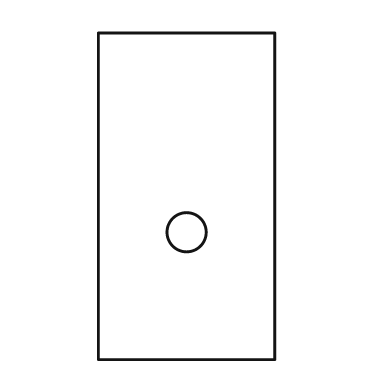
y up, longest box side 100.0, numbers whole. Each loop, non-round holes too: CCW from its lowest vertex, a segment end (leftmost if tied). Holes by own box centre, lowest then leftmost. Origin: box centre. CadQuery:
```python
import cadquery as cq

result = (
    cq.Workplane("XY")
    .moveTo(-27.0, -50.0)
    .lineTo(27.0, -50.0)
    .lineTo(27.0, 50.0)
    .lineTo(-27.0, 50.0)
    .close()
    .moveTo(0.0, -11.0)
    .circle(6.0)
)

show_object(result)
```